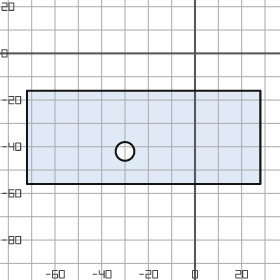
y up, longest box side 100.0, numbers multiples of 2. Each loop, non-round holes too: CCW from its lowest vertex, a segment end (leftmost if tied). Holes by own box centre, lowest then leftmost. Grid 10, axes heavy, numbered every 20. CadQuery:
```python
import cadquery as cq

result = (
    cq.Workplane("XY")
    .moveTo(-72.0, -56.0)
    .lineTo(28.0, -56.0)
    .lineTo(28.0, -16.0)
    .lineTo(-72.0, -16.0)
    .close()
    .moveTo(-30.0, -42.0)
    .circle(4.0)
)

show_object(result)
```